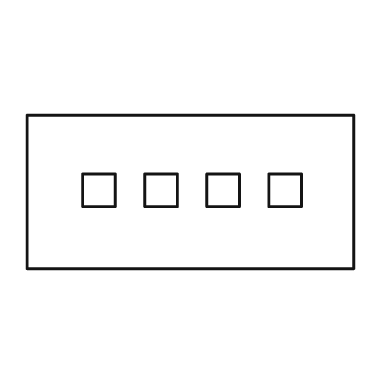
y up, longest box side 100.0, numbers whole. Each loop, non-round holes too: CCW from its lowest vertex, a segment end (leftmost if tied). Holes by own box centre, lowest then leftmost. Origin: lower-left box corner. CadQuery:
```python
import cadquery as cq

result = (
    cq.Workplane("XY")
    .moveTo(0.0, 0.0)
    .lineTo(100.0, 0.0)
    .lineTo(100.0, 47.0)
    .lineTo(0.0, 47.0)
    .close()
    .moveTo(17.0, 19.0)
    .lineTo(27.0, 19.0)
    .lineTo(27.0, 29.0)
    .lineTo(17.0, 29.0)
    .close()
    .moveTo(36.0, 19.0)
    .lineTo(46.0, 19.0)
    .lineTo(46.0, 29.0)
    .lineTo(36.0, 29.0)
    .close()
    .moveTo(55.0, 19.0)
    .lineTo(65.0, 19.0)
    .lineTo(65.0, 29.0)
    .lineTo(55.0, 29.0)
    .close()
    .moveTo(74.0, 19.0)
    .lineTo(84.0, 19.0)
    .lineTo(84.0, 29.0)
    .lineTo(74.0, 29.0)
    .close()
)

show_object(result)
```